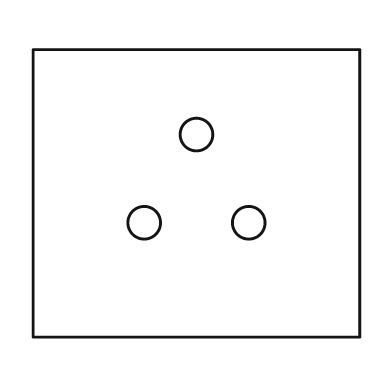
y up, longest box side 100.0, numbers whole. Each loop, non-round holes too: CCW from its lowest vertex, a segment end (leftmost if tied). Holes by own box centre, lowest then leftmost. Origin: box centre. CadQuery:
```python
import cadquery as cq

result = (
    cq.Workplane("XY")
    .moveTo(-50.0, -44.0)
    .lineTo(50.0, -44.0)
    .lineTo(50.0, 44.0)
    .lineTo(-50.0, 44.0)
    .close()
    .moveTo(-16.0, -9.0)
    .circle(5.0)
    .moveTo(16.0, -9.0)
    .circle(5.0)
    .moveTo(0.0, 18.0)
    .circle(5.0)
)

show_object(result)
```